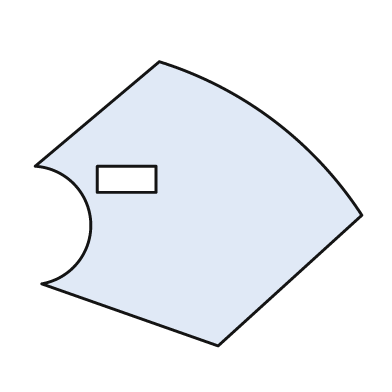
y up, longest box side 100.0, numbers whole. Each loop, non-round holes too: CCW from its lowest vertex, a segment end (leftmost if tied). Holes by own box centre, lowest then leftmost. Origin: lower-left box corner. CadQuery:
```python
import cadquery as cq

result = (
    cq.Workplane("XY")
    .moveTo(56.0, 0.0)
    .lineTo(100.0, 40.0)
    .threePointArc((73.0, 69.0), (38.0, 87.0))
    .lineTo(0.0, 55.0)
    .threePointArc((17.0, 38.0), (2.0, 19.0))
    .close()
    .moveTo(19.0, 47.0)
    .lineTo(37.0, 47.0)
    .lineTo(37.0, 55.0)
    .lineTo(19.0, 55.0)
    .close()
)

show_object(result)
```